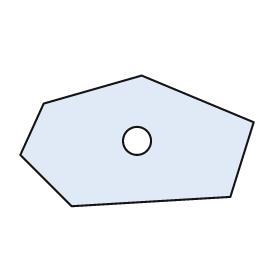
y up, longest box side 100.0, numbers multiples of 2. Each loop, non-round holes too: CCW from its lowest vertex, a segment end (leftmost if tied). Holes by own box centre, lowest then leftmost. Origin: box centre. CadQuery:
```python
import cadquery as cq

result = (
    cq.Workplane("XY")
    .moveTo(-28.0, -28.0)
    .lineTo(40.0, -24.0)
    .lineTo(50.0, 8.0)
    .lineTo(2.0, 28.0)
    .lineTo(-40.0, 16.0)
    .lineTo(-50.0, -6.0)
    .close()
    .moveTo(0.0, 0.0)
    .circle(6.0)
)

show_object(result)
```